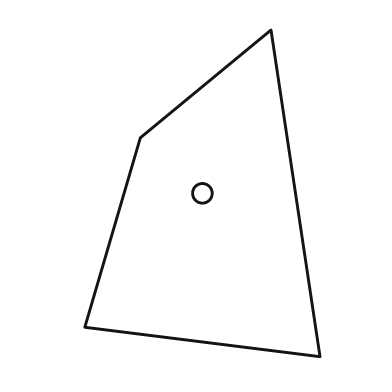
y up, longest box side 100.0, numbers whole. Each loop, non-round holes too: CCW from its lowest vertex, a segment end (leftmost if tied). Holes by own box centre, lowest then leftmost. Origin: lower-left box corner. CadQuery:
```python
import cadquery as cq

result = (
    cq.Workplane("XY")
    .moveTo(72.0, 0.0)
    .lineTo(57.0, 100.0)
    .lineTo(17.0, 67.0)
    .lineTo(0.0, 9.0)
    .close()
    .moveTo(36.0, 50.0)
    .circle(3.0)
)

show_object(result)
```